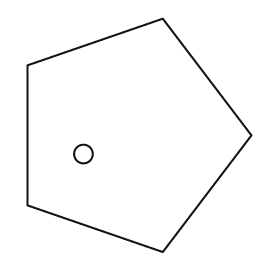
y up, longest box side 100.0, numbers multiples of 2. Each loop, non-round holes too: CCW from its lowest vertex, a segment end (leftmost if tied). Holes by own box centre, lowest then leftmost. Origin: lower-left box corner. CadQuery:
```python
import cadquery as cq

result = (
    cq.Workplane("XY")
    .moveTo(58.0, 0.0)
    .lineTo(96.0, 50.0)
    .lineTo(58.0, 100.0)
    .lineTo(0.0, 80.0)
    .lineTo(0.0, 20.0)
    .close()
    .moveTo(24.0, 42.0)
    .circle(4.0)
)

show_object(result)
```